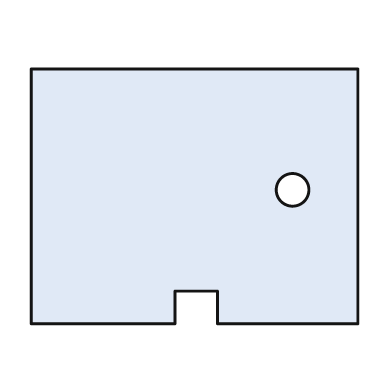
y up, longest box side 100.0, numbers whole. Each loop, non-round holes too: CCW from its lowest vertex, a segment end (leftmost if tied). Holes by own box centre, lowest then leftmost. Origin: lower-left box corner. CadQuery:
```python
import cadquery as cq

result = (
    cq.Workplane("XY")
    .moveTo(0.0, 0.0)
    .lineTo(44.0, 0.0)
    .lineTo(44.0, 10.0)
    .lineTo(57.0, 10.0)
    .lineTo(57.0, 0.0)
    .lineTo(100.0, 0.0)
    .lineTo(100.0, 78.0)
    .lineTo(0.0, 78.0)
    .close()
    .moveTo(80.0, 41.0)
    .circle(5.0)
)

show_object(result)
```